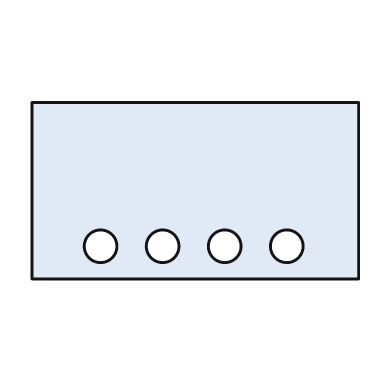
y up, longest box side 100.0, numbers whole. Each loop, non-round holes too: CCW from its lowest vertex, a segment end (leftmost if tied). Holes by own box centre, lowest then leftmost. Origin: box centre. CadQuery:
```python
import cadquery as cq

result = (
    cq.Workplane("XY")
    .moveTo(-50.0, -27.0)
    .lineTo(50.0, -27.0)
    .lineTo(50.0, 27.0)
    .lineTo(-50.0, 27.0)
    .close()
    .moveTo(-29.0, -17.0)
    .circle(5.0)
    .moveTo(-10.0, -17.0)
    .circle(5.0)
    .moveTo(9.0, -17.0)
    .circle(5.0)
    .moveTo(28.0, -17.0)
    .circle(5.0)
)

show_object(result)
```